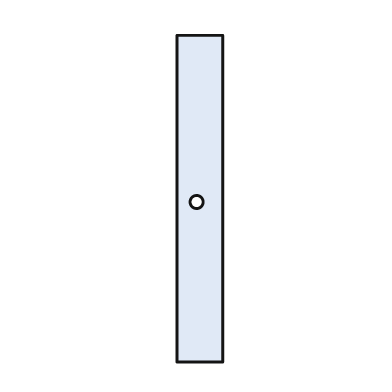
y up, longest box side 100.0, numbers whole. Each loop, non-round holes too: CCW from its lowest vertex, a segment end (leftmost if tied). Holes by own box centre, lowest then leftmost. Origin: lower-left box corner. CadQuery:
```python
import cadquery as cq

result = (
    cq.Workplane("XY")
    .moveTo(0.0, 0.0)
    .lineTo(14.0, 0.0)
    .lineTo(14.0, 100.0)
    .lineTo(0.0, 100.0)
    .close()
    .moveTo(6.0, 49.0)
    .circle(2.0)
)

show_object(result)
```